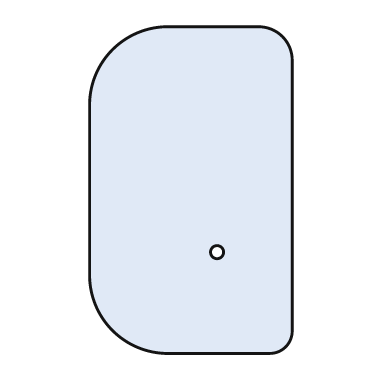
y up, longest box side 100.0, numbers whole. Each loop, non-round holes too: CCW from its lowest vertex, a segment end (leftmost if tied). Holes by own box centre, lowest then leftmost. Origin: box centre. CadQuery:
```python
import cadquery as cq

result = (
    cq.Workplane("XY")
    .moveTo(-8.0, -50.0)
    .lineTo(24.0, -50.0)
    .threePointArc((29.0, -48.0), (31.0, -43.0))
    .lineTo(31.0, 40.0)
    .threePointArc((28.0, 47.0), (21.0, 50.0))
    .lineTo(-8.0, 50.0)
    .threePointArc((-24.0, 43.0), (-31.0, 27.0))
    .lineTo(-31.0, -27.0)
    .threePointArc((-24.0, -43.0), (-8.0, -50.0))
    .close()
    .moveTo(8.0, -19.0)
    .circle(2.0)
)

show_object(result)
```